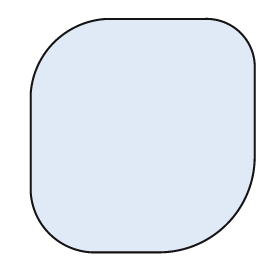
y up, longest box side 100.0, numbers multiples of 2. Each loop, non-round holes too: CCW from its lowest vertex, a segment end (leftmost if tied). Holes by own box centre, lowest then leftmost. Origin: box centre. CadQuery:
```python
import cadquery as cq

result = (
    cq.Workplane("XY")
    .moveTo(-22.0, -50.0)
    .lineTo(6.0, -50.0)
    .threePointArc((36.0, -38.0), (48.0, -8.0))
    .lineTo(48.0, 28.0)
    .threePointArc((42.0, 44.0), (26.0, 50.0))
    .lineTo(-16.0, 50.0)
    .threePointArc((-38.0, 40.0), (-48.0, 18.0))
    .lineTo(-48.0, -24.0)
    .threePointArc((-40.0, -42.0), (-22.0, -50.0))
    .close()
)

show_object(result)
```